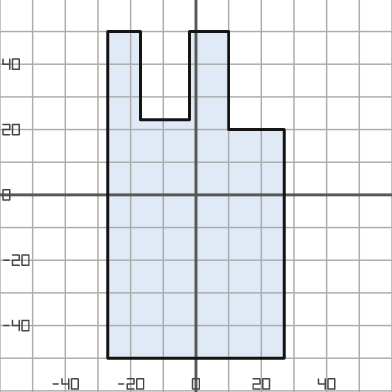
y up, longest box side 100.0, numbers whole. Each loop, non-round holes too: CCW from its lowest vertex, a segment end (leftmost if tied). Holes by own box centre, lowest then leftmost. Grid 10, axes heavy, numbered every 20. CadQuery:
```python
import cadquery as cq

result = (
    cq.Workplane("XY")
    .moveTo(-27.0, -50.0)
    .lineTo(27.0, -50.0)
    .lineTo(27.0, 20.0)
    .lineTo(10.0, 20.0)
    .lineTo(10.0, 50.0)
    .lineTo(-2.0, 50.0)
    .lineTo(-2.0, 23.0)
    .lineTo(-17.0, 23.0)
    .lineTo(-17.0, 50.0)
    .lineTo(-27.0, 50.0)
    .close()
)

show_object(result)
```